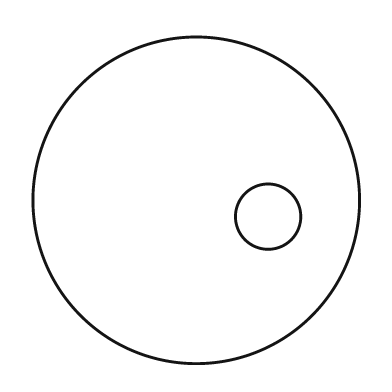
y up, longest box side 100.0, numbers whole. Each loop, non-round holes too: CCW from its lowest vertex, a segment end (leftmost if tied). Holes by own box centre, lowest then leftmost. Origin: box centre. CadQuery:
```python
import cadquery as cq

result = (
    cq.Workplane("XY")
    .moveTo(0.0, 0.0)
    .circle(50.0)
    .moveTo(22.0, -5.0)
    .circle(10.0)
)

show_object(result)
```